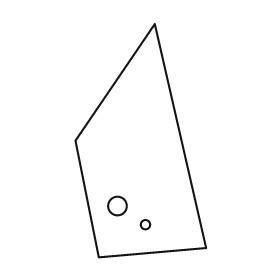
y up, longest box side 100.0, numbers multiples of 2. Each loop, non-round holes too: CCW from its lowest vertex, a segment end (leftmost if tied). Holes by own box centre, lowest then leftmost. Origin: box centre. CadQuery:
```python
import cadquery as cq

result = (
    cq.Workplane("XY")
    .moveTo(-18.0, -50.0)
    .lineTo(28.0, -46.0)
    .lineTo(6.0, 50.0)
    .lineTo(-28.0, 0.0)
    .close()
    .moveTo(2.0, -36.0)
    .circle(2.0)
    .moveTo(-10.0, -28.0)
    .circle(4.0)
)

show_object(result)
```